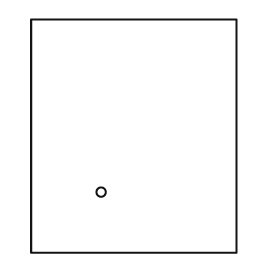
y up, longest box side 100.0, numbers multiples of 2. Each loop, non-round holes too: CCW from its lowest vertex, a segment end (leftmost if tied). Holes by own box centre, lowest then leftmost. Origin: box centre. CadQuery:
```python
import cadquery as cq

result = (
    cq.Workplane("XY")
    .moveTo(-44.0, -50.0)
    .lineTo(44.0, -50.0)
    .lineTo(44.0, 50.0)
    .lineTo(-44.0, 50.0)
    .close()
    .moveTo(-14.0, -24.0)
    .circle(2.0)
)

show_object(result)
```